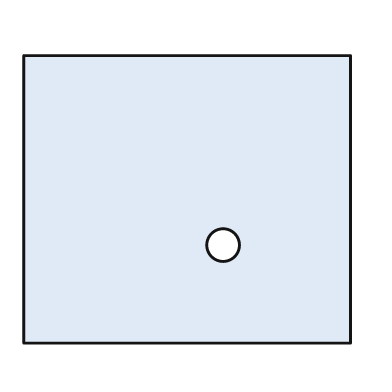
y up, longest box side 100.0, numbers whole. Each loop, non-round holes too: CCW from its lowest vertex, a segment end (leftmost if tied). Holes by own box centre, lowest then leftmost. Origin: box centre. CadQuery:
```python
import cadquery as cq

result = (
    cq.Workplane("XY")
    .moveTo(-50.0, -44.0)
    .lineTo(50.0, -44.0)
    .lineTo(50.0, 44.0)
    .lineTo(-50.0, 44.0)
    .close()
    .moveTo(11.0, -14.0)
    .circle(5.0)
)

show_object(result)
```